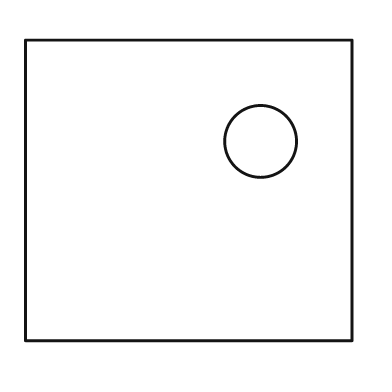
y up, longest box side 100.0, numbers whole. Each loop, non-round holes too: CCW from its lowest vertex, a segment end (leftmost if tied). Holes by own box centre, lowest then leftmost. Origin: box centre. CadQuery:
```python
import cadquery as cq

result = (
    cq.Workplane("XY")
    .moveTo(-50.0, -46.0)
    .lineTo(50.0, -46.0)
    .lineTo(50.0, 46.0)
    .lineTo(-50.0, 46.0)
    .close()
    .moveTo(22.0, 15.0)
    .circle(11.0)
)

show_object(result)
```